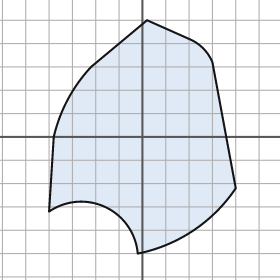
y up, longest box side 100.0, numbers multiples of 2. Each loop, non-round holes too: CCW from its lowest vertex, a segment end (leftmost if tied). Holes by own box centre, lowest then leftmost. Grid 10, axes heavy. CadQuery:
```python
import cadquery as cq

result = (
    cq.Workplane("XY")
    .moveTo(-2.0, -50.0)
    .threePointArc((22.0, -40.0), (40.0, -22.0))
    .lineTo(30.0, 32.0)
    .threePointArc((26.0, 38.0), (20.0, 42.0))
    .lineTo(2.0, 50.0)
    .lineTo(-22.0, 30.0)
    .threePointArc((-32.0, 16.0), (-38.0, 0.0))
    .lineTo(-40.0, -32.0)
    .threePointArc((-16.0, -30.0), (-2.0, -50.0))
    .close()
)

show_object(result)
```